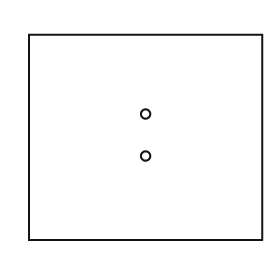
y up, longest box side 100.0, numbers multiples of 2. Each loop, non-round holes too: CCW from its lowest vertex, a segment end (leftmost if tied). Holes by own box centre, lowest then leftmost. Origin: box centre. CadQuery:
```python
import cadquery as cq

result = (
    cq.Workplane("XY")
    .moveTo(-50.0, -44.0)
    .lineTo(50.0, -44.0)
    .lineTo(50.0, 44.0)
    .lineTo(-50.0, 44.0)
    .close()
    .moveTo(0.0, -8.0)
    .circle(2.0)
    .moveTo(0.0, 10.0)
    .circle(2.0)
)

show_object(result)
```